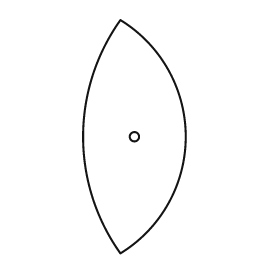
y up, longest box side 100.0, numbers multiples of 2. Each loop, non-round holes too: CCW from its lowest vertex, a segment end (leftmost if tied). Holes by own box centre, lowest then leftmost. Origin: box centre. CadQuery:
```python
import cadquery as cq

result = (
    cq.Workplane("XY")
    .moveTo(-6.0, -50.0)
    .threePointArc((22.0, 0.0), (-6.0, 50.0))
    .threePointArc((-22.0, 0.0), (-6.0, -50.0))
    .close()
    .moveTo(0.0, 0.0)
    .circle(2.0)
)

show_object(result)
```